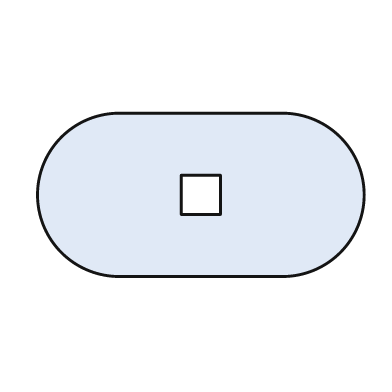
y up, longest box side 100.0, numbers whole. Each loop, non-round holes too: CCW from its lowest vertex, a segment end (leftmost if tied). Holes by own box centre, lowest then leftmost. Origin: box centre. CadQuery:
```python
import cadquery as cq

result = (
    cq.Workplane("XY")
    .moveTo(-25.0, -25.0)
    .lineTo(25.0, -25.0)
    .threePointArc((50.0, 0.0), (25.0, 25.0))
    .lineTo(-25.0, 25.0)
    .threePointArc((-50.0, 0.0), (-25.0, -25.0))
    .close()
    .moveTo(-6.0, -6.0)
    .lineTo(6.0, -6.0)
    .lineTo(6.0, 6.0)
    .lineTo(-6.0, 6.0)
    .close()
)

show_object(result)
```